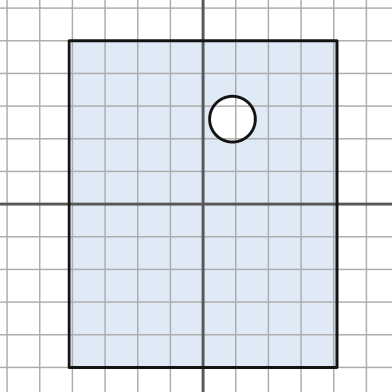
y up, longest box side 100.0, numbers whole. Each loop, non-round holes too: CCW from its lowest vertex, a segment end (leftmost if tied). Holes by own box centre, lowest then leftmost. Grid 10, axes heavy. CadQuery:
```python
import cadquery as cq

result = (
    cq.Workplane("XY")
    .moveTo(-41.0, -50.0)
    .lineTo(41.0, -50.0)
    .lineTo(41.0, 50.0)
    .lineTo(-41.0, 50.0)
    .close()
    .moveTo(9.0, 26.0)
    .circle(7.0)
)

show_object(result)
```